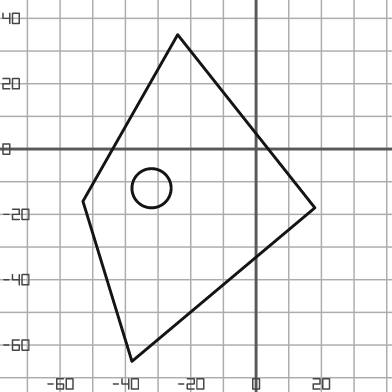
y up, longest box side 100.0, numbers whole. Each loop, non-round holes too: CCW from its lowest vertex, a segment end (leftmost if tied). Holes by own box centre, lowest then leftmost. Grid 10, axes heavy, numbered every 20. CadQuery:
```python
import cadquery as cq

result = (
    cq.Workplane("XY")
    .moveTo(-38.0, -65.0)
    .lineTo(18.0, -18.0)
    .lineTo(-24.0, 35.0)
    .lineTo(-53.0, -16.0)
    .close()
    .moveTo(-32.0, -12.0)
    .circle(6.0)
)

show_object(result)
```